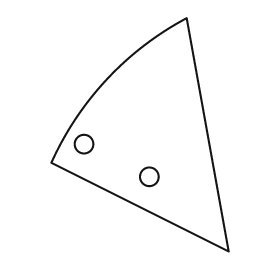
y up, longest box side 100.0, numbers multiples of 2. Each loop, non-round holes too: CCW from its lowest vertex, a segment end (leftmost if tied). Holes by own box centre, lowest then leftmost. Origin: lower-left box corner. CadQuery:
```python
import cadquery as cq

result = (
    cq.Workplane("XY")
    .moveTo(76.0, 0.0)
    .lineTo(58.0, 100.0)
    .threePointArc((24.0, 74.0), (0.0, 38.0))
    .close()
    .moveTo(42.0, 32.0)
    .circle(4.0)
    .moveTo(14.0, 46.0)
    .circle(4.0)
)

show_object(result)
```